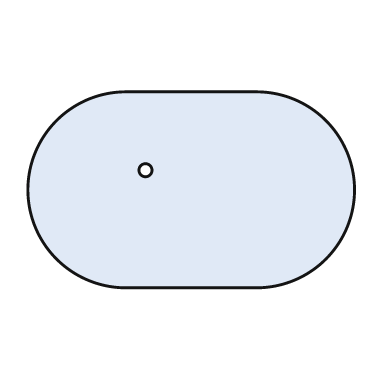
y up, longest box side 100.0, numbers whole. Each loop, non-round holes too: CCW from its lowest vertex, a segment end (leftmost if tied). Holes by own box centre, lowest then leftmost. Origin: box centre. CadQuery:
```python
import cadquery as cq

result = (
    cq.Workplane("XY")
    .moveTo(-20.0, -30.0)
    .lineTo(20.0, -30.0)
    .threePointArc((50.0, 0.0), (20.0, 30.0))
    .lineTo(-20.0, 30.0)
    .threePointArc((-50.0, 0.0), (-20.0, -30.0))
    .close()
    .moveTo(-14.0, 6.0)
    .circle(2.0)
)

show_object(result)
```